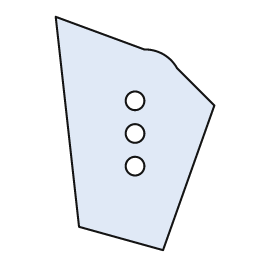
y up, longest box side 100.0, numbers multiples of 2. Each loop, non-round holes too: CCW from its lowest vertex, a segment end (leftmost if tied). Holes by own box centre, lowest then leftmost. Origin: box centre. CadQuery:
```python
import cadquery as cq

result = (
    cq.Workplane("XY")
    .moveTo(12.0, -50.0)
    .lineTo(34.0, 12.0)
    .lineTo(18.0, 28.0)
    .threePointArc((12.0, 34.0), (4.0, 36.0))
    .lineTo(-34.0, 50.0)
    .lineTo(-24.0, -40.0)
    .close()
    .moveTo(0.0, -14.0)
    .circle(4.0)
    .moveTo(0.0, 0.0)
    .circle(4.0)
    .moveTo(0.0, 14.0)
    .circle(4.0)
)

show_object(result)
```